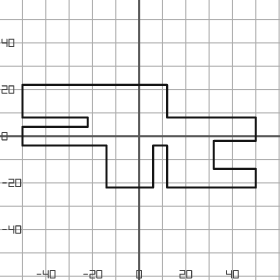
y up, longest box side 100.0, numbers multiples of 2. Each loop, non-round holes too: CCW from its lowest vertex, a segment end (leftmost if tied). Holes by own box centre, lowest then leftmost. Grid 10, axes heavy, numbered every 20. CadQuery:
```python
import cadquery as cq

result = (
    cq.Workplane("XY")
    .moveTo(-14.0, -22.0)
    .lineTo(6.0, -22.0)
    .lineTo(6.0, -4.0)
    .lineTo(12.0, -4.0)
    .lineTo(12.0, -22.0)
    .lineTo(50.0, -22.0)
    .lineTo(50.0, -14.0)
    .lineTo(32.0, -14.0)
    .lineTo(32.0, -2.0)
    .lineTo(50.0, -2.0)
    .lineTo(50.0, 8.0)
    .lineTo(12.0, 8.0)
    .lineTo(12.0, 22.0)
    .lineTo(-50.0, 22.0)
    .lineTo(-50.0, 8.0)
    .lineTo(-22.0, 8.0)
    .lineTo(-22.0, 4.0)
    .lineTo(-50.0, 4.0)
    .lineTo(-50.0, -4.0)
    .lineTo(-14.0, -4.0)
    .close()
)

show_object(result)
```